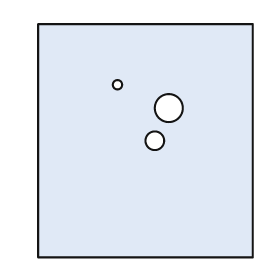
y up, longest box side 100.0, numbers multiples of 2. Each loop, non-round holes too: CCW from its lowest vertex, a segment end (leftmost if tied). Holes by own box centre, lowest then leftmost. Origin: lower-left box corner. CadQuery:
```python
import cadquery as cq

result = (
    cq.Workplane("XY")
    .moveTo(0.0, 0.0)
    .lineTo(92.0, 0.0)
    .lineTo(92.0, 100.0)
    .lineTo(0.0, 100.0)
    .close()
    .moveTo(50.0, 50.0)
    .circle(4.0)
    .moveTo(56.0, 64.0)
    .circle(6.0)
    .moveTo(34.0, 74.0)
    .circle(2.0)
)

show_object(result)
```